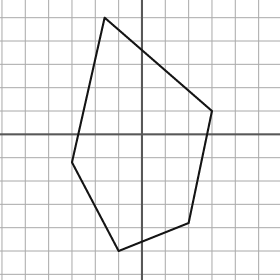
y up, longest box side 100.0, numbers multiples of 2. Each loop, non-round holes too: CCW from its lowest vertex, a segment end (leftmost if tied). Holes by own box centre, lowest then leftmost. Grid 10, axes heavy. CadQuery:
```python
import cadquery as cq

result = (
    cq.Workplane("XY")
    .moveTo(-10.0, -50.0)
    .lineTo(20.0, -38.0)
    .lineTo(30.0, 10.0)
    .lineTo(-16.0, 50.0)
    .lineTo(-30.0, -12.0)
    .close()
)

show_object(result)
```